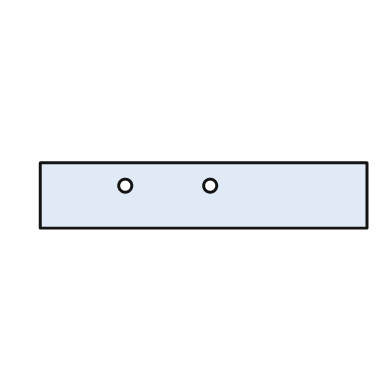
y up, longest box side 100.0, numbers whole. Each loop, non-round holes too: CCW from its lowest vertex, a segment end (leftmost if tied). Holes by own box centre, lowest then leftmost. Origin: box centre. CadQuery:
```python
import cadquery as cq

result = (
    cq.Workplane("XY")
    .moveTo(-50.0, -10.0)
    .lineTo(50.0, -10.0)
    .lineTo(50.0, 10.0)
    .lineTo(-50.0, 10.0)
    .close()
    .moveTo(-24.0, 3.0)
    .circle(2.0)
    .moveTo(2.0, 3.0)
    .circle(2.0)
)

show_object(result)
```